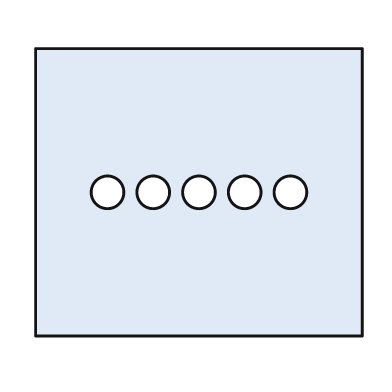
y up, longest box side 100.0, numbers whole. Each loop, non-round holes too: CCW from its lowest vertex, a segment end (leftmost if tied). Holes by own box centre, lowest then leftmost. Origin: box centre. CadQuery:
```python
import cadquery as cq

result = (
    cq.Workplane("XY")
    .moveTo(-50.0, -44.0)
    .lineTo(50.0, -44.0)
    .lineTo(50.0, 44.0)
    .lineTo(-50.0, 44.0)
    .close()
    .moveTo(-28.0, 0.0)
    .circle(5.0)
    .moveTo(-14.0, 0.0)
    .circle(5.0)
    .moveTo(0.0, 0.0)
    .circle(5.0)
    .moveTo(14.0, 0.0)
    .circle(5.0)
    .moveTo(28.0, 0.0)
    .circle(5.0)
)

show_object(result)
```